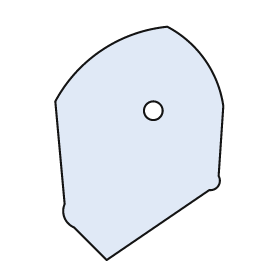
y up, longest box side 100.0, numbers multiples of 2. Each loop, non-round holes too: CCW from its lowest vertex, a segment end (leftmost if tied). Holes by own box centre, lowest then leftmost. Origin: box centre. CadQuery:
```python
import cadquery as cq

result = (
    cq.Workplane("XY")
    .moveTo(-14.0, -50.0)
    .lineTo(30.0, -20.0)
    .threePointArc((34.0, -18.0), (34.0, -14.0))
    .lineTo(36.0, 16.0)
    .threePointArc((28.0, 36.0), (12.0, 50.0))
    .threePointArc((-16.0, 40.0), (-36.0, 18.0))
    .lineTo(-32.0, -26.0)
    .threePointArc((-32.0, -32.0), (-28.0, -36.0))
    .close()
    .moveTo(6.0, 14.0)
    .circle(4.0)
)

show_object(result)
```